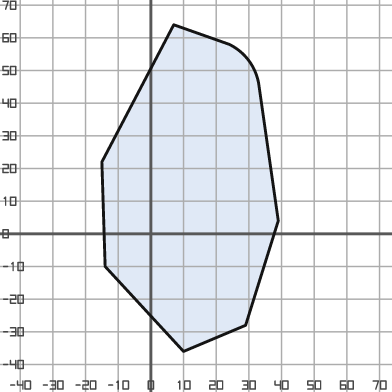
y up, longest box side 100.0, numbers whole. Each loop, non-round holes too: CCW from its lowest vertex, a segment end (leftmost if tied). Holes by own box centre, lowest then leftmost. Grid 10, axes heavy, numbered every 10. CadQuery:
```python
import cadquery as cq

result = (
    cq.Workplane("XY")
    .moveTo(10.0, -36.0)
    .lineTo(29.0, -28.0)
    .lineTo(39.0, 4.0)
    .lineTo(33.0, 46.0)
    .threePointArc((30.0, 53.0), (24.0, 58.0))
    .lineTo(7.0, 64.0)
    .lineTo(-15.0, 22.0)
    .lineTo(-14.0, -10.0)
    .close()
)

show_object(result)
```